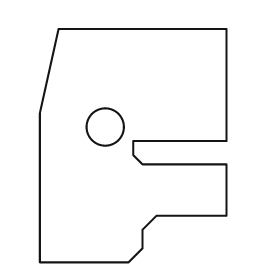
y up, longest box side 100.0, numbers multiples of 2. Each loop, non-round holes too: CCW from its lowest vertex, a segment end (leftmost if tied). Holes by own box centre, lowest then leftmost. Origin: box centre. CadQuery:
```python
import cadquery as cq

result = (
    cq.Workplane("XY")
    .moveTo(-40.0, -50.0)
    .lineTo(-2.0, -50.0)
    .lineTo(4.0, -44.0)
    .lineTo(4.0, -36.0)
    .lineTo(10.0, -30.0)
    .lineTo(40.0, -30.0)
    .lineTo(40.0, -8.0)
    .lineTo(4.0, -8.0)
    .lineTo(0.0, -4.0)
    .lineTo(0.0, 2.0)
    .lineTo(40.0, 2.0)
    .lineTo(40.0, 50.0)
    .lineTo(-32.0, 50.0)
    .lineTo(-40.0, 14.0)
    .close()
    .moveTo(-12.0, 8.0)
    .circle(8.0)
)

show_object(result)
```